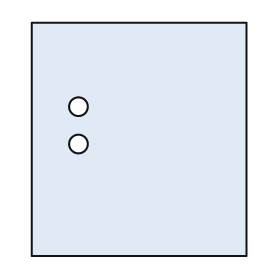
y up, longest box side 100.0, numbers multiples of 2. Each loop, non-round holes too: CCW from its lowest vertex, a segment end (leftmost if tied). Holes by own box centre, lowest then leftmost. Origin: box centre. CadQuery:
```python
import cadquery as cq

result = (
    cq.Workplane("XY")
    .moveTo(-46.0, -50.0)
    .lineTo(46.0, -50.0)
    .lineTo(46.0, 50.0)
    .lineTo(-46.0, 50.0)
    .close()
    .moveTo(-26.0, -2.0)
    .circle(4.0)
    .moveTo(-26.0, 14.0)
    .circle(4.0)
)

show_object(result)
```